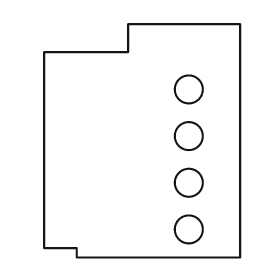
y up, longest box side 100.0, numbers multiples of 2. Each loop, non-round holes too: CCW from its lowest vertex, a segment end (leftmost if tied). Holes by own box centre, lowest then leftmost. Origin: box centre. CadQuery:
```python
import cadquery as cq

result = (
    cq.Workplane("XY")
    .moveTo(-28.0, -50.0)
    .lineTo(42.0, -50.0)
    .lineTo(42.0, 50.0)
    .lineTo(-6.0, 50.0)
    .lineTo(-6.0, 38.0)
    .lineTo(-42.0, 38.0)
    .lineTo(-42.0, -46.0)
    .lineTo(-28.0, -46.0)
    .close()
    .moveTo(20.0, -38.0)
    .circle(6.0)
    .moveTo(20.0, -18.0)
    .circle(6.0)
    .moveTo(20.0, 2.0)
    .circle(6.0)
    .moveTo(20.0, 22.0)
    .circle(6.0)
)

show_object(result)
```